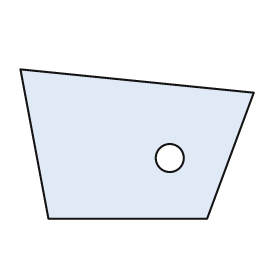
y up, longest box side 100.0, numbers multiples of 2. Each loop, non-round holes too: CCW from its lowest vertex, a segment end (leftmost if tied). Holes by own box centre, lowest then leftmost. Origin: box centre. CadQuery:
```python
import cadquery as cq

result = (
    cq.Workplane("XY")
    .moveTo(-38.0, -32.0)
    .lineTo(30.0, -32.0)
    .lineTo(50.0, 22.0)
    .lineTo(-50.0, 32.0)
    .close()
    .moveTo(14.0, -6.0)
    .circle(6.0)
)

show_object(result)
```